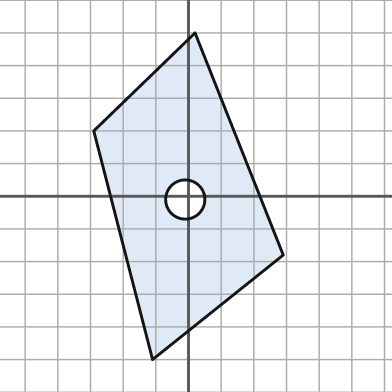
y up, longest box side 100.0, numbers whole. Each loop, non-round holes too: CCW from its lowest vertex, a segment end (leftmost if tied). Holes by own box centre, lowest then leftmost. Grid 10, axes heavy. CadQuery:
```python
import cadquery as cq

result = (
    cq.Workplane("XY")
    .moveTo(-11.0, -50.0)
    .lineTo(29.0, -18.0)
    .lineTo(2.0, 50.0)
    .lineTo(-29.0, 20.0)
    .close()
    .moveTo(-1.0, -1.0)
    .circle(6.0)
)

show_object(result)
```